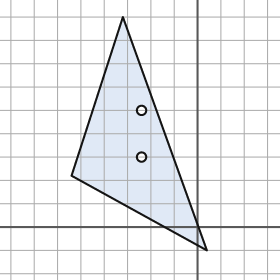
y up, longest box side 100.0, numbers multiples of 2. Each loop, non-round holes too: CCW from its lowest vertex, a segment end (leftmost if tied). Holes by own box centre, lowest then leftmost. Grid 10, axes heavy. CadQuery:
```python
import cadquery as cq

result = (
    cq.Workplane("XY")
    .moveTo(4.0, -10.0)
    .lineTo(-32.0, 90.0)
    .lineTo(-54.0, 22.0)
    .close()
    .moveTo(-24.0, 30.0)
    .circle(2.0)
    .moveTo(-24.0, 50.0)
    .circle(2.0)
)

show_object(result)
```